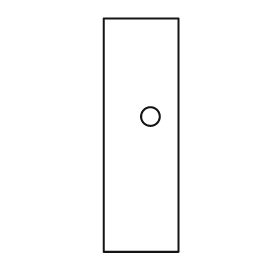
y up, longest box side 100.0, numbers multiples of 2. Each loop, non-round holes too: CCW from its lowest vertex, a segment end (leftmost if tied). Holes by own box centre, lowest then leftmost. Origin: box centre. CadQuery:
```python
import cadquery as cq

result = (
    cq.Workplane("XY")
    .moveTo(-16.0, -50.0)
    .lineTo(16.0, -50.0)
    .lineTo(16.0, 50.0)
    .lineTo(-16.0, 50.0)
    .close()
    .moveTo(4.0, 8.0)
    .circle(4.0)
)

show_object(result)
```